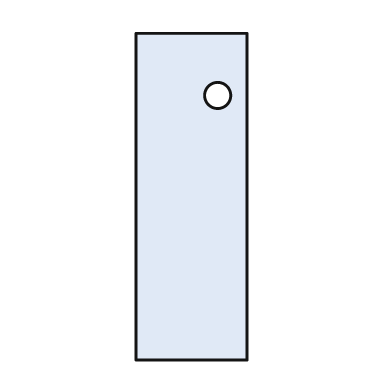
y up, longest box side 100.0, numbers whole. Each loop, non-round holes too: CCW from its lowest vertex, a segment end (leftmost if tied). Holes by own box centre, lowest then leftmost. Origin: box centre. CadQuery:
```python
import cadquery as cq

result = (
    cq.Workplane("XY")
    .moveTo(-17.0, -50.0)
    .lineTo(17.0, -50.0)
    .lineTo(17.0, 50.0)
    .lineTo(-17.0, 50.0)
    .close()
    .moveTo(8.0, 31.0)
    .circle(4.0)
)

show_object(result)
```